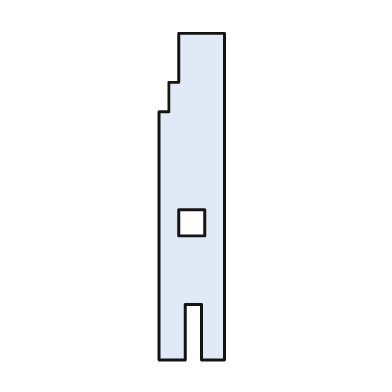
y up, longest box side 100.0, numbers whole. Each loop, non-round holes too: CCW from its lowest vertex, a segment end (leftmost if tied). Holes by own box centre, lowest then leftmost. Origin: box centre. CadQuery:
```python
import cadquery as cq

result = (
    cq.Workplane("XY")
    .moveTo(-10.0, -50.0)
    .lineTo(-2.0, -50.0)
    .lineTo(-2.0, -33.0)
    .lineTo(3.0, -33.0)
    .lineTo(3.0, -50.0)
    .lineTo(10.0, -50.0)
    .lineTo(10.0, 50.0)
    .lineTo(-4.0, 50.0)
    .lineTo(-4.0, 35.0)
    .lineTo(-7.0, 35.0)
    .lineTo(-7.0, 26.0)
    .lineTo(-10.0, 26.0)
    .close()
    .moveTo(-4.0, -12.0)
    .lineTo(4.0, -12.0)
    .lineTo(4.0, -4.0)
    .lineTo(-4.0, -4.0)
    .close()
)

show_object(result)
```